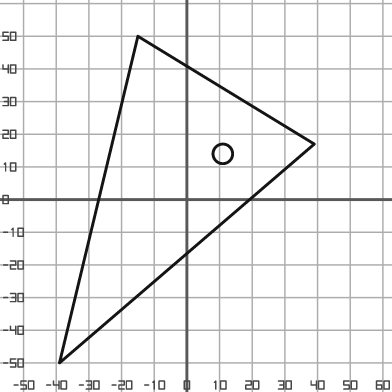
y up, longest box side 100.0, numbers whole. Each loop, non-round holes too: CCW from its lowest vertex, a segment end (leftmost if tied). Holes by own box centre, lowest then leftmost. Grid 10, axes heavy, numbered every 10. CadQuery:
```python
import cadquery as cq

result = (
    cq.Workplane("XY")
    .moveTo(-39.0, -50.0)
    .lineTo(39.0, 17.0)
    .lineTo(-15.0, 50.0)
    .close()
    .moveTo(11.0, 14.0)
    .circle(3.0)
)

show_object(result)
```